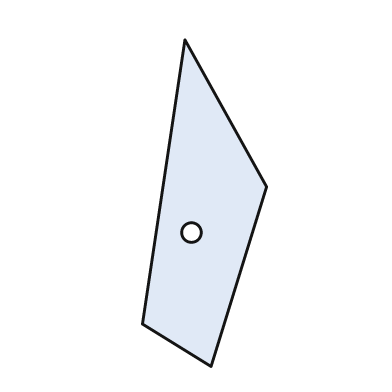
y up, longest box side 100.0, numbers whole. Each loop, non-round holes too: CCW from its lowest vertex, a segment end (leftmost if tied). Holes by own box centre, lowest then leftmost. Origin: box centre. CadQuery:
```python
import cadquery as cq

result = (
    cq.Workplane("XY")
    .moveTo(2.0, -50.0)
    .lineTo(19.0, 5.0)
    .lineTo(-6.0, 50.0)
    .lineTo(-19.0, -37.0)
    .close()
    .moveTo(-4.0, -9.0)
    .circle(3.0)
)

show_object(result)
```